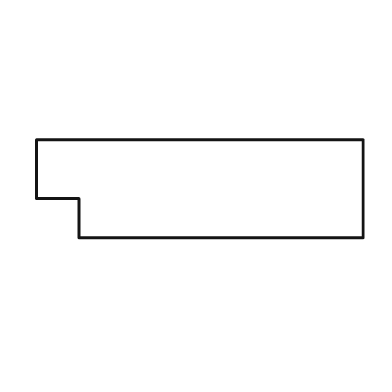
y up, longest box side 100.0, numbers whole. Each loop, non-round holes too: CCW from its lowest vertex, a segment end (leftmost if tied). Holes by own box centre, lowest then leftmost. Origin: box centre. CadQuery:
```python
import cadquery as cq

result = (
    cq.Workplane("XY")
    .moveTo(-37.0, -15.0)
    .lineTo(50.0, -15.0)
    .lineTo(50.0, 15.0)
    .lineTo(-50.0, 15.0)
    .lineTo(-50.0, -3.0)
    .lineTo(-37.0, -3.0)
    .close()
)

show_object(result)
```